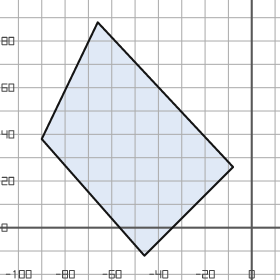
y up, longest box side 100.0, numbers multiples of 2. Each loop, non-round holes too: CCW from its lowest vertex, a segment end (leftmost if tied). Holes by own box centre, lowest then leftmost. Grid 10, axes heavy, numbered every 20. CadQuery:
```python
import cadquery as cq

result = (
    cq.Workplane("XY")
    .moveTo(-46.0, -12.0)
    .lineTo(-8.0, 26.0)
    .lineTo(-66.0, 88.0)
    .lineTo(-90.0, 38.0)
    .close()
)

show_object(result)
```